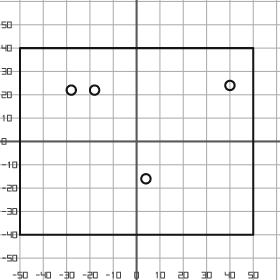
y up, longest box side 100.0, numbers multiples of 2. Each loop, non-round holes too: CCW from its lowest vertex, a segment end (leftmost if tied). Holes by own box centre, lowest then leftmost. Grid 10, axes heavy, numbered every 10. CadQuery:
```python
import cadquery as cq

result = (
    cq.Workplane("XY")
    .moveTo(-50.0, -40.0)
    .lineTo(50.0, -40.0)
    .lineTo(50.0, 40.0)
    .lineTo(-50.0, 40.0)
    .close()
    .moveTo(4.0, -16.0)
    .circle(2.0)
    .moveTo(-28.0, 22.0)
    .circle(2.0)
    .moveTo(-18.0, 22.0)
    .circle(2.0)
    .moveTo(40.0, 24.0)
    .circle(2.0)
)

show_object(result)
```